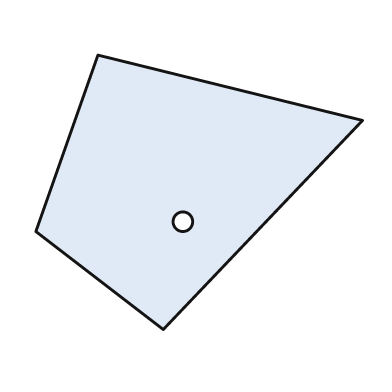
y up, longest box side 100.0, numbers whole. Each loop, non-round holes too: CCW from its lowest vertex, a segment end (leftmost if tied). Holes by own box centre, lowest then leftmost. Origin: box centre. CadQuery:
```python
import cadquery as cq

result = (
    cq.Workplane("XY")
    .moveTo(-11.0, -42.0)
    .lineTo(50.0, 22.0)
    .lineTo(-31.0, 42.0)
    .lineTo(-50.0, -12.0)
    .close()
    .moveTo(-5.0, -9.0)
    .circle(3.0)
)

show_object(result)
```